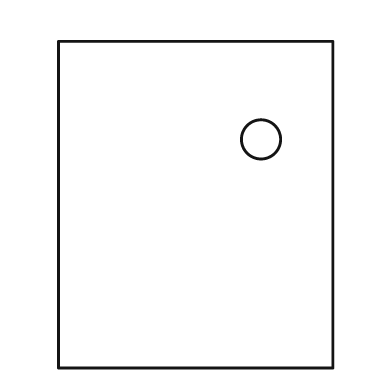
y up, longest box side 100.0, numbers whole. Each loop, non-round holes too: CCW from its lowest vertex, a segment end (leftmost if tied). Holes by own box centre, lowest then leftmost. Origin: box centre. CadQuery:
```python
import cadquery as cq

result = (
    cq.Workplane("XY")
    .moveTo(-42.0, -50.0)
    .lineTo(42.0, -50.0)
    .lineTo(42.0, 50.0)
    .lineTo(-42.0, 50.0)
    .close()
    .moveTo(20.0, 20.0)
    .circle(6.0)
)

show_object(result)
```